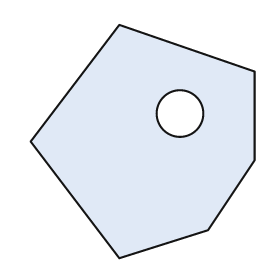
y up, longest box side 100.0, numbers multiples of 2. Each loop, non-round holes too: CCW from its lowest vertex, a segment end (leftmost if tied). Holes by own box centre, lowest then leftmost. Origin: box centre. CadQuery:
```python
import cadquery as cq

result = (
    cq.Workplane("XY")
    .moveTo(-10.0, -50.0)
    .lineTo(28.0, -38.0)
    .lineTo(48.0, -8.0)
    .lineTo(48.0, 30.0)
    .lineTo(-10.0, 50.0)
    .lineTo(-48.0, 0.0)
    .close()
    .moveTo(16.0, 12.0)
    .circle(10.0)
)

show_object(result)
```